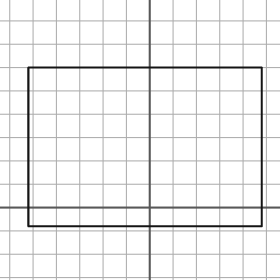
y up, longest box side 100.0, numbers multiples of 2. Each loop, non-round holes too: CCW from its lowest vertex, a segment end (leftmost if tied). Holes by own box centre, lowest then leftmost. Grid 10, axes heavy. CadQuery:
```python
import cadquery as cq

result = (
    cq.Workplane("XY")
    .moveTo(-52.0, -8.0)
    .lineTo(48.0, -8.0)
    .lineTo(48.0, 60.0)
    .lineTo(-52.0, 60.0)
    .close()
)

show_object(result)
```